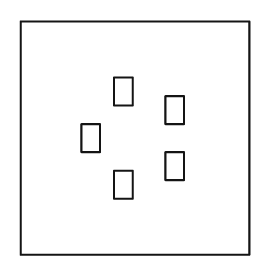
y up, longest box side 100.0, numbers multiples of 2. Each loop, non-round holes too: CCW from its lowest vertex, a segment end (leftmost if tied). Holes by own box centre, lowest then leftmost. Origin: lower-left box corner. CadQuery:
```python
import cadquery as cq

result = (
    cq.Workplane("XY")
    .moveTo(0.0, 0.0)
    .lineTo(98.0, 0.0)
    .lineTo(98.0, 100.0)
    .lineTo(0.0, 100.0)
    .close()
    .moveTo(40.0, 24.0)
    .lineTo(48.0, 24.0)
    .lineTo(48.0, 36.0)
    .lineTo(40.0, 36.0)
    .close()
    .moveTo(62.0, 32.0)
    .lineTo(70.0, 32.0)
    .lineTo(70.0, 44.0)
    .lineTo(62.0, 44.0)
    .close()
    .moveTo(26.0, 44.0)
    .lineTo(34.0, 44.0)
    .lineTo(34.0, 56.0)
    .lineTo(26.0, 56.0)
    .close()
    .moveTo(62.0, 56.0)
    .lineTo(70.0, 56.0)
    .lineTo(70.0, 68.0)
    .lineTo(62.0, 68.0)
    .close()
    .moveTo(40.0, 64.0)
    .lineTo(48.0, 64.0)
    .lineTo(48.0, 76.0)
    .lineTo(40.0, 76.0)
    .close()
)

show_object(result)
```